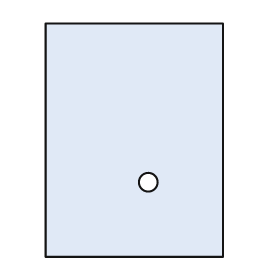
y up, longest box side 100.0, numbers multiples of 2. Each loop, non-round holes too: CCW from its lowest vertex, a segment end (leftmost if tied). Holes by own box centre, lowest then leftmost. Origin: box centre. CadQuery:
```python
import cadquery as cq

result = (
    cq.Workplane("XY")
    .moveTo(-38.0, -50.0)
    .lineTo(38.0, -50.0)
    .lineTo(38.0, 50.0)
    .lineTo(-38.0, 50.0)
    .close()
    .moveTo(6.0, -18.0)
    .circle(4.0)
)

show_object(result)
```